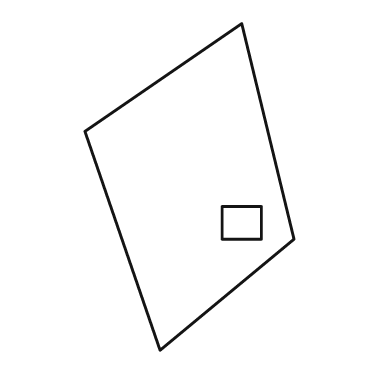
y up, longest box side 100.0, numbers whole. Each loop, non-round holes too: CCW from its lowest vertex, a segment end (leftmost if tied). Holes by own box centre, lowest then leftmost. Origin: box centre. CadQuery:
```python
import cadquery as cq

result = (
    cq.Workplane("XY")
    .moveTo(-9.0, -50.0)
    .lineTo(32.0, -16.0)
    .lineTo(16.0, 50.0)
    .lineTo(-32.0, 17.0)
    .close()
    .moveTo(10.0, -16.0)
    .lineTo(22.0, -16.0)
    .lineTo(22.0, -6.0)
    .lineTo(10.0, -6.0)
    .close()
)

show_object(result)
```